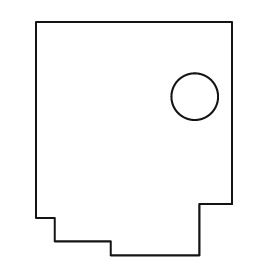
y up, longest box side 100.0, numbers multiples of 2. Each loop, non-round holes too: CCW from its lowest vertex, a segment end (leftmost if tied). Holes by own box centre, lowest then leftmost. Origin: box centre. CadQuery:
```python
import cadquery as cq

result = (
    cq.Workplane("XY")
    .moveTo(-10.0, -50.0)
    .lineTo(28.0, -50.0)
    .lineTo(28.0, -28.0)
    .lineTo(42.0, -28.0)
    .lineTo(42.0, 50.0)
    .lineTo(-42.0, 50.0)
    .lineTo(-42.0, -34.0)
    .lineTo(-34.0, -34.0)
    .lineTo(-34.0, -44.0)
    .lineTo(-10.0, -44.0)
    .close()
    .moveTo(26.0, 18.0)
    .circle(10.0)
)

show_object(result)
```